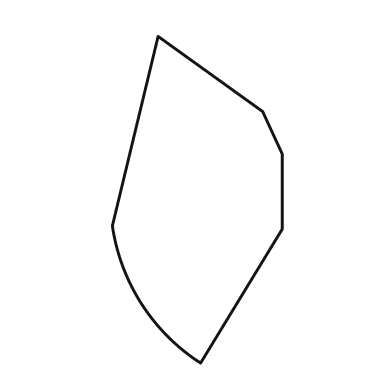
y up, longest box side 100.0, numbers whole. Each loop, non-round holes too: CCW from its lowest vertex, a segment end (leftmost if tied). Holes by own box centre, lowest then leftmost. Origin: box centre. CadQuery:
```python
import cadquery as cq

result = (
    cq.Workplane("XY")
    .moveTo(1.0, -50.0)
    .lineTo(26.0, -9.0)
    .lineTo(26.0, 14.0)
    .lineTo(20.0, 27.0)
    .lineTo(-12.0, 50.0)
    .lineTo(-26.0, -8.0)
    .threePointArc((-17.0, -32.0), (1.0, -50.0))
    .close()
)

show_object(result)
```